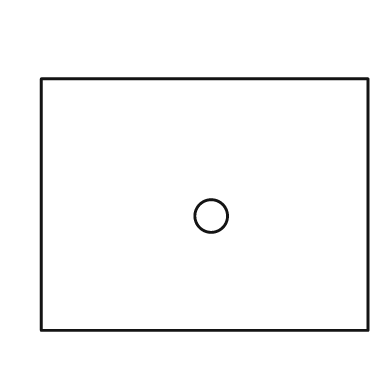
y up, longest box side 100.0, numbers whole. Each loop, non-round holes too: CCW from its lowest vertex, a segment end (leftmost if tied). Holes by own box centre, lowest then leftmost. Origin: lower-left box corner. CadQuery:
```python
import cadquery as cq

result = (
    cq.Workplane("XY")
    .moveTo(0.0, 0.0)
    .lineTo(100.0, 0.0)
    .lineTo(100.0, 77.0)
    .lineTo(0.0, 77.0)
    .close()
    .moveTo(52.0, 35.0)
    .circle(5.0)
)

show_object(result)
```